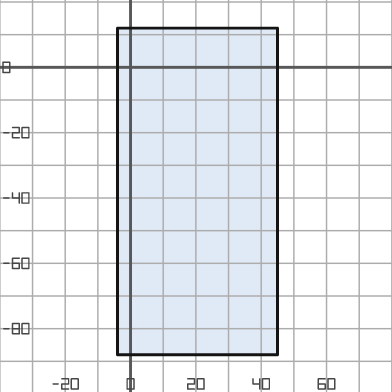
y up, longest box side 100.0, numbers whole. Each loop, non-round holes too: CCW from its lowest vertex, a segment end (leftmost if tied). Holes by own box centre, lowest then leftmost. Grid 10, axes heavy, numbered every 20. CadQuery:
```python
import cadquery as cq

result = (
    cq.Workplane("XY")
    .moveTo(-4.0, -88.0)
    .lineTo(45.0, -88.0)
    .lineTo(45.0, 12.0)
    .lineTo(-4.0, 12.0)
    .close()
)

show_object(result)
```